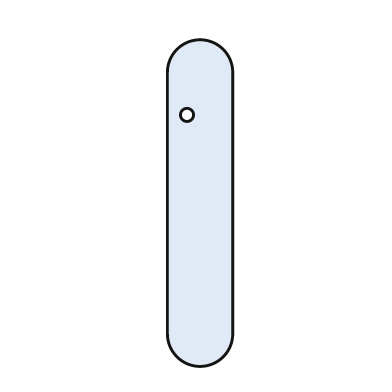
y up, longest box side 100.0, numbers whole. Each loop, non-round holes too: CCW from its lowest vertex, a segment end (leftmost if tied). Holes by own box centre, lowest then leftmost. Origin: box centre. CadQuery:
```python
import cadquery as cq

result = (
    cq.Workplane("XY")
    .moveTo(-10.0, -40.0)
    .threePointArc((0.0, -50.0), (10.0, -40.0))
    .lineTo(10.0, 40.0)
    .threePointArc((0.0, 50.0), (-10.0, 40.0))
    .close()
    .moveTo(-4.0, 27.0)
    .circle(2.0)
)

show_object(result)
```